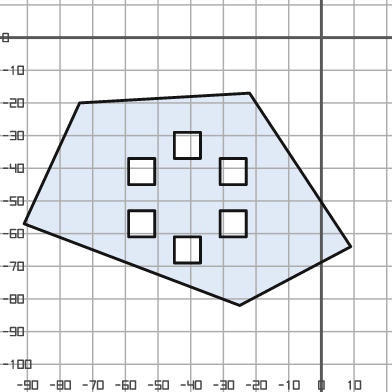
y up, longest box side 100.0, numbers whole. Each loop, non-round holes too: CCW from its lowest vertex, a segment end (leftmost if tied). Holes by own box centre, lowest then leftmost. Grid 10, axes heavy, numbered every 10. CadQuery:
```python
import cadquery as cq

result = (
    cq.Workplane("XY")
    .moveTo(-25.0, -82.0)
    .lineTo(9.0, -64.0)
    .lineTo(-22.0, -17.0)
    .lineTo(-74.0, -20.0)
    .lineTo(-91.0, -57.0)
    .close()
    .moveTo(-45.0, -69.0)
    .lineTo(-37.0, -69.0)
    .lineTo(-37.0, -61.0)
    .lineTo(-45.0, -61.0)
    .close()
    .moveTo(-59.0, -61.0)
    .lineTo(-51.0, -61.0)
    .lineTo(-51.0, -53.0)
    .lineTo(-59.0, -53.0)
    .close()
    .moveTo(-31.0, -61.0)
    .lineTo(-23.0, -61.0)
    .lineTo(-23.0, -53.0)
    .lineTo(-31.0, -53.0)
    .close()
    .moveTo(-59.0, -45.0)
    .lineTo(-51.0, -45.0)
    .lineTo(-51.0, -37.0)
    .lineTo(-59.0, -37.0)
    .close()
    .moveTo(-31.0, -45.0)
    .lineTo(-23.0, -45.0)
    .lineTo(-23.0, -37.0)
    .lineTo(-31.0, -37.0)
    .close()
    .moveTo(-45.0, -37.0)
    .lineTo(-37.0, -37.0)
    .lineTo(-37.0, -29.0)
    .lineTo(-45.0, -29.0)
    .close()
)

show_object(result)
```